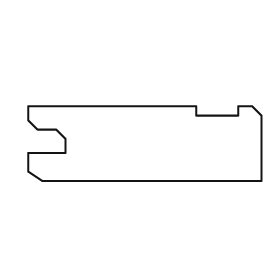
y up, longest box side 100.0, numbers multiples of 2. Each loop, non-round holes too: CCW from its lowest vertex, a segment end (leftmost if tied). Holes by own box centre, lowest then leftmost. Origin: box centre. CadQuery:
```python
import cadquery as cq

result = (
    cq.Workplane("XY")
    .moveTo(-44.0, -16.0)
    .lineTo(50.0, -16.0)
    .lineTo(50.0, 12.0)
    .lineTo(46.0, 16.0)
    .lineTo(40.0, 16.0)
    .lineTo(40.0, 12.0)
    .lineTo(22.0, 12.0)
    .lineTo(22.0, 16.0)
    .lineTo(-50.0, 16.0)
    .lineTo(-50.0, 10.0)
    .lineTo(-46.0, 6.0)
    .lineTo(-38.0, 6.0)
    .lineTo(-34.0, 2.0)
    .lineTo(-34.0, -4.0)
    .lineTo(-50.0, -4.0)
    .lineTo(-50.0, -12.0)
    .close()
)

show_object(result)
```